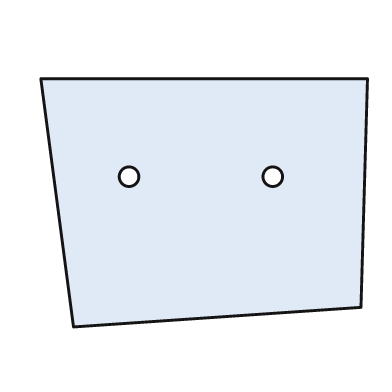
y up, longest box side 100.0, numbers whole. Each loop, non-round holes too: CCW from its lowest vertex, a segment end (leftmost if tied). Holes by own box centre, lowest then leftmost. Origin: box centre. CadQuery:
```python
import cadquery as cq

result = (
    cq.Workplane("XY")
    .moveTo(-40.0, -38.0)
    .lineTo(48.0, -32.0)
    .lineTo(50.0, 38.0)
    .lineTo(-50.0, 38.0)
    .close()
    .moveTo(-23.0, 8.0)
    .circle(3.0)
    .moveTo(21.0, 8.0)
    .circle(3.0)
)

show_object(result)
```